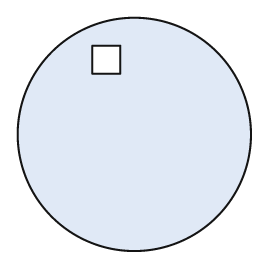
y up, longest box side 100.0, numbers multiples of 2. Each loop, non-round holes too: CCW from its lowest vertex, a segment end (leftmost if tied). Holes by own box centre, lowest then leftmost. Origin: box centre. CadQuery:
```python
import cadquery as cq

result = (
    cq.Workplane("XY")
    .moveTo(0.0, 0.0)
    .circle(50.0)
    .moveTo(-18.0, 26.0)
    .lineTo(-6.0, 26.0)
    .lineTo(-6.0, 38.0)
    .lineTo(-18.0, 38.0)
    .close()
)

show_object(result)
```